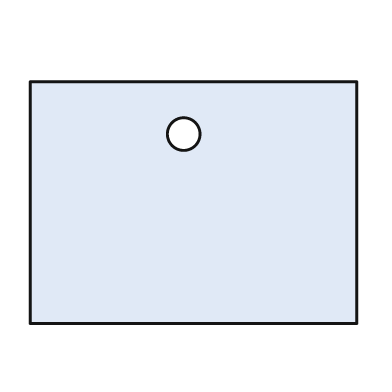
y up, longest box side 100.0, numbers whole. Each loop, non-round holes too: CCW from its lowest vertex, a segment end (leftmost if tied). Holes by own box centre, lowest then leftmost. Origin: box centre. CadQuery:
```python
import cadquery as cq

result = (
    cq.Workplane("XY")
    .moveTo(-50.0, -37.0)
    .lineTo(50.0, -37.0)
    .lineTo(50.0, 37.0)
    .lineTo(-50.0, 37.0)
    .close()
    .moveTo(-3.0, 21.0)
    .circle(5.0)
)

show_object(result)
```